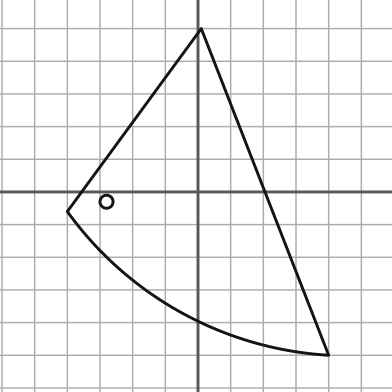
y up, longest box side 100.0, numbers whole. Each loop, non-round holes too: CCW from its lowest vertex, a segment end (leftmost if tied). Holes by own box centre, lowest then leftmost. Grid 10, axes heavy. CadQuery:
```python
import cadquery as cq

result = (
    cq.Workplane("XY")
    .moveTo(40.0, -50.0)
    .lineTo(1.0, 50.0)
    .lineTo(-40.0, -6.0)
    .threePointArc((-5.0, -37.0), (40.0, -50.0))
    .close()
    .moveTo(-28.0, -3.0)
    .circle(2.0)
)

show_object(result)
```